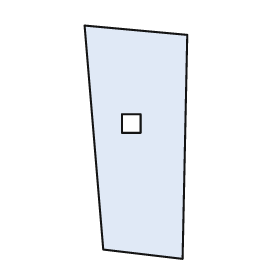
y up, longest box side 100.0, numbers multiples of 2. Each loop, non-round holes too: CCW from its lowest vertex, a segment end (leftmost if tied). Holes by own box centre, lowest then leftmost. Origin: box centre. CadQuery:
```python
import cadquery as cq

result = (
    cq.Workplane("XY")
    .moveTo(20.0, -50.0)
    .lineTo(22.0, 46.0)
    .lineTo(-22.0, 50.0)
    .lineTo(-14.0, -46.0)
    .close()
    .moveTo(-6.0, 4.0)
    .lineTo(2.0, 4.0)
    .lineTo(2.0, 12.0)
    .lineTo(-6.0, 12.0)
    .close()
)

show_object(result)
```